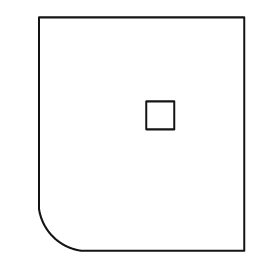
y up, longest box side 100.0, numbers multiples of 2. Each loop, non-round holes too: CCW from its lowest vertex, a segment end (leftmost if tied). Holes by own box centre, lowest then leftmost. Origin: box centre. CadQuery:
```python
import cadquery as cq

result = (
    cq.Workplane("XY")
    .moveTo(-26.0, -50.0)
    .lineTo(44.0, -50.0)
    .lineTo(44.0, 50.0)
    .lineTo(-44.0, 50.0)
    .lineTo(-44.0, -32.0)
    .threePointArc((-38.0, -44.0), (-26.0, -50.0))
    .close()
    .moveTo(2.0, 2.0)
    .lineTo(14.0, 2.0)
    .lineTo(14.0, 14.0)
    .lineTo(2.0, 14.0)
    .close()
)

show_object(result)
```